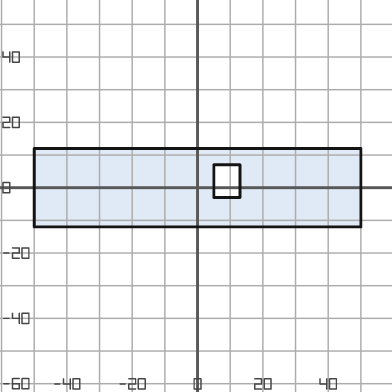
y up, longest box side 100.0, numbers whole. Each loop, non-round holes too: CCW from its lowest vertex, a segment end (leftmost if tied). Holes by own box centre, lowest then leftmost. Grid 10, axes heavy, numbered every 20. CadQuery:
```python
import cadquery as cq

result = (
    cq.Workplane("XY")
    .moveTo(-50.0, -12.0)
    .lineTo(50.0, -12.0)
    .lineTo(50.0, 12.0)
    .lineTo(-50.0, 12.0)
    .close()
    .moveTo(5.0, -3.0)
    .lineTo(13.0, -3.0)
    .lineTo(13.0, 7.0)
    .lineTo(5.0, 7.0)
    .close()
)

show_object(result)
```